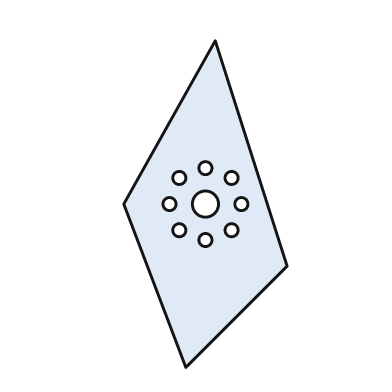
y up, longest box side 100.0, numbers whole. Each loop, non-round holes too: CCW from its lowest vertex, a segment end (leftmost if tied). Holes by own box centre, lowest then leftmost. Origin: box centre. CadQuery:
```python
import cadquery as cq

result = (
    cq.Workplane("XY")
    .moveTo(-6.0, -50.0)
    .lineTo(25.0, -19.0)
    .lineTo(3.0, 50.0)
    .lineTo(-25.0, 0.0)
    .close()
    .moveTo(0.0, -11.0)
    .circle(2.0)
    .moveTo(-8.0, -8.0)
    .circle(2.0)
    .moveTo(8.0, -8.0)
    .circle(2.0)
    .moveTo(-11.0, 0.0)
    .circle(2.0)
    .moveTo(0.0, 0.0)
    .circle(4.0)
    .moveTo(11.0, 0.0)
    .circle(2.0)
    .moveTo(-8.0, 8.0)
    .circle(2.0)
    .moveTo(8.0, 8.0)
    .circle(2.0)
    .moveTo(0.0, 11.0)
    .circle(2.0)
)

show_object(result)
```